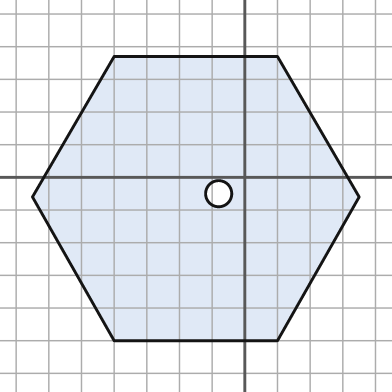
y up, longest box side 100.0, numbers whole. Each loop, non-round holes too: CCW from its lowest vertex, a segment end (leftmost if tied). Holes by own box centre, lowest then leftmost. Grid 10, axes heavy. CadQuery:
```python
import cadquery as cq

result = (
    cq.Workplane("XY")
    .moveTo(-40.0, -50.0)
    .lineTo(10.0, -50.0)
    .lineTo(35.0, -6.0)
    .lineTo(10.0, 37.0)
    .lineTo(-40.0, 37.0)
    .lineTo(-65.0, -6.0)
    .close()
    .moveTo(-8.0, -5.0)
    .circle(4.0)
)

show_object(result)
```